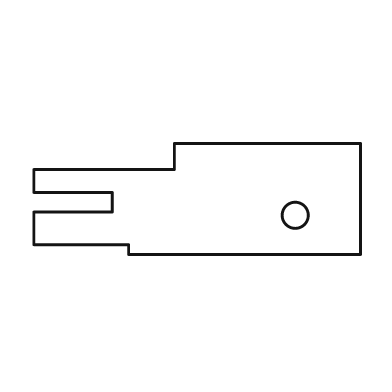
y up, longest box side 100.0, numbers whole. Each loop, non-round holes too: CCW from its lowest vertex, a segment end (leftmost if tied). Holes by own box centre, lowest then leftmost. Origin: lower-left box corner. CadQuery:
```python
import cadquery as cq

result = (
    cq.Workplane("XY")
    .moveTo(29.0, 0.0)
    .lineTo(100.0, 0.0)
    .lineTo(100.0, 34.0)
    .lineTo(43.0, 34.0)
    .lineTo(43.0, 26.0)
    .lineTo(0.0, 26.0)
    .lineTo(0.0, 19.0)
    .lineTo(24.0, 19.0)
    .lineTo(24.0, 13.0)
    .lineTo(0.0, 13.0)
    .lineTo(0.0, 3.0)
    .lineTo(29.0, 3.0)
    .close()
    .moveTo(80.0, 12.0)
    .circle(4.0)
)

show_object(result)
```